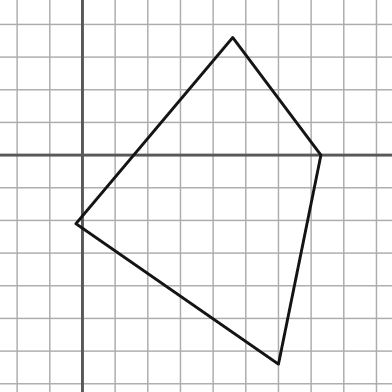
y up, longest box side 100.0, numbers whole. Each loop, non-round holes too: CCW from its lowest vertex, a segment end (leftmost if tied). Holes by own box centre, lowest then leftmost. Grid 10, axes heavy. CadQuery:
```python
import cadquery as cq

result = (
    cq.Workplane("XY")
    .moveTo(60.0, -64.0)
    .lineTo(73.0, 0.0)
    .lineTo(46.0, 36.0)
    .lineTo(-2.0, -21.0)
    .close()
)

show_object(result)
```